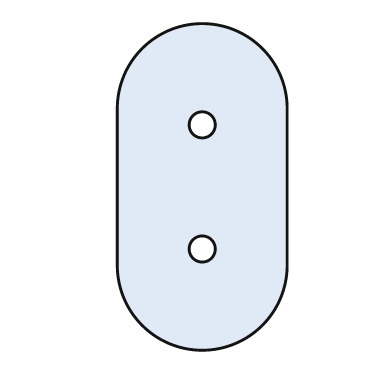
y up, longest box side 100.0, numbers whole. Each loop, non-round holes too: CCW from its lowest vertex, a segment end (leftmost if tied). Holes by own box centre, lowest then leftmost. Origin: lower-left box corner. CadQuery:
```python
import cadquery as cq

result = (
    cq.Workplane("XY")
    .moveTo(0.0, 26.0)
    .threePointArc((26.0, 0.0), (52.0, 26.0))
    .lineTo(52.0, 74.0)
    .threePointArc((26.0, 100.0), (0.0, 74.0))
    .close()
    .moveTo(26.0, 31.0)
    .circle(4.0)
    .moveTo(26.0, 69.0)
    .circle(4.0)
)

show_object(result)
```